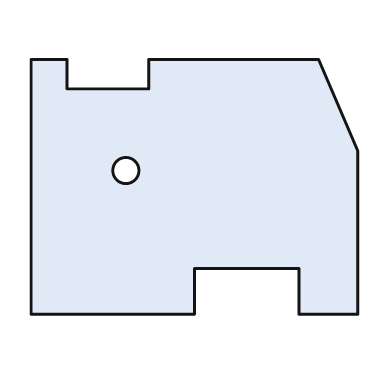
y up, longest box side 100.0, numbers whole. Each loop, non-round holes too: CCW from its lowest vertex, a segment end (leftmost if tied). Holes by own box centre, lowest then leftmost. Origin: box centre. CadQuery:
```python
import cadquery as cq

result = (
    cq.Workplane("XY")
    .moveTo(-50.0, -39.0)
    .lineTo(0.0, -39.0)
    .lineTo(0.0, -25.0)
    .lineTo(32.0, -25.0)
    .lineTo(32.0, -39.0)
    .lineTo(50.0, -39.0)
    .lineTo(50.0, 11.0)
    .lineTo(38.0, 39.0)
    .lineTo(-14.0, 39.0)
    .lineTo(-14.0, 30.0)
    .lineTo(-39.0, 30.0)
    .lineTo(-39.0, 39.0)
    .lineTo(-50.0, 39.0)
    .close()
    .moveTo(-21.0, 5.0)
    .circle(4.0)
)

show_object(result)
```